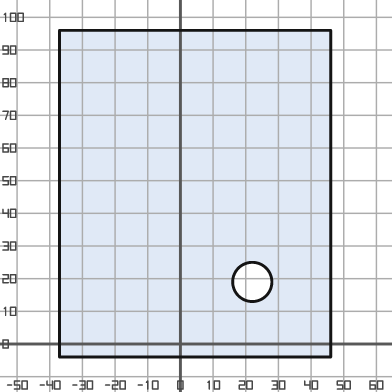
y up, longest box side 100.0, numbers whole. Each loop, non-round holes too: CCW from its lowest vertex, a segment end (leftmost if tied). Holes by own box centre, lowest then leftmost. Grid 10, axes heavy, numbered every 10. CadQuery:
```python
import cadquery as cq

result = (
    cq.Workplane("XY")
    .moveTo(-37.0, -4.0)
    .lineTo(46.0, -4.0)
    .lineTo(46.0, 96.0)
    .lineTo(-37.0, 96.0)
    .close()
    .moveTo(22.0, 19.0)
    .circle(6.0)
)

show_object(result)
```